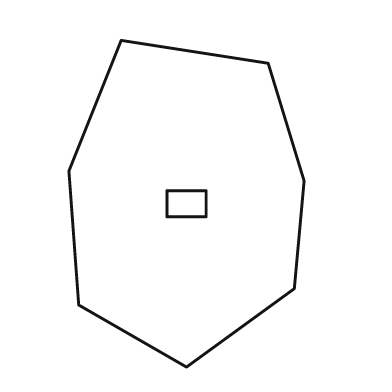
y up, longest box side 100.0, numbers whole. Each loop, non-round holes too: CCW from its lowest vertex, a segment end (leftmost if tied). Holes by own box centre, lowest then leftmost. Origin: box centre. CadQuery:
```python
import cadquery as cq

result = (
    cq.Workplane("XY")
    .moveTo(0.0, -50.0)
    .lineTo(33.0, -26.0)
    .lineTo(36.0, 7.0)
    .lineTo(25.0, 43.0)
    .lineTo(-20.0, 50.0)
    .lineTo(-36.0, 10.0)
    .lineTo(-33.0, -31.0)
    .close()
    .moveTo(-6.0, -4.0)
    .lineTo(6.0, -4.0)
    .lineTo(6.0, 4.0)
    .lineTo(-6.0, 4.0)
    .close()
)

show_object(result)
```